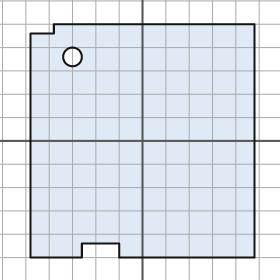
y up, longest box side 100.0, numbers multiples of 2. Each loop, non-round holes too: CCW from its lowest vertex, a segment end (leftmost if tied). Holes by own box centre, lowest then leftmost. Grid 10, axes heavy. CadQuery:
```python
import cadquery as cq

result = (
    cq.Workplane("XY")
    .moveTo(-48.0, -50.0)
    .lineTo(-26.0, -50.0)
    .lineTo(-26.0, -44.0)
    .lineTo(-10.0, -44.0)
    .lineTo(-10.0, -50.0)
    .lineTo(48.0, -50.0)
    .lineTo(48.0, 50.0)
    .lineTo(-38.0, 50.0)
    .lineTo(-38.0, 46.0)
    .lineTo(-48.0, 46.0)
    .close()
    .moveTo(-30.0, 36.0)
    .circle(4.0)
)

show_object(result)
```